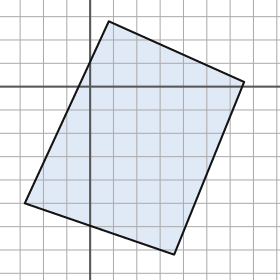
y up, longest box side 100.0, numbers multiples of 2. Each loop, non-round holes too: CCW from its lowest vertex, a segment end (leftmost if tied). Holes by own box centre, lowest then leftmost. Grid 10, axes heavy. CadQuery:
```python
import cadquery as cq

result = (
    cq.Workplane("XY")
    .moveTo(36.0, -72.0)
    .lineTo(66.0, 2.0)
    .lineTo(8.0, 28.0)
    .lineTo(-28.0, -50.0)
    .close()
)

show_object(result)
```